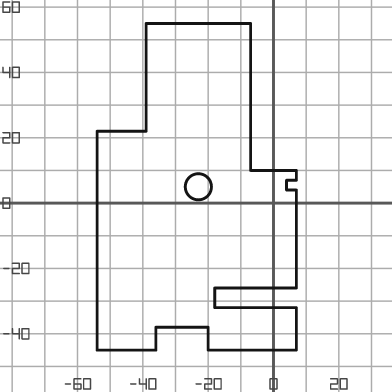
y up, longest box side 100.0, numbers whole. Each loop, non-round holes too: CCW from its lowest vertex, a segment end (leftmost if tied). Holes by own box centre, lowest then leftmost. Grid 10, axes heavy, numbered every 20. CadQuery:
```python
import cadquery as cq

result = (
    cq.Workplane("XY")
    .moveTo(-54.0, -45.0)
    .lineTo(-36.0, -45.0)
    .lineTo(-36.0, -38.0)
    .lineTo(-20.0, -38.0)
    .lineTo(-20.0, -45.0)
    .lineTo(7.0, -45.0)
    .lineTo(7.0, -32.0)
    .lineTo(-18.0, -32.0)
    .lineTo(-18.0, -26.0)
    .lineTo(7.0, -26.0)
    .lineTo(7.0, 4.0)
    .lineTo(4.0, 4.0)
    .lineTo(4.0, 7.0)
    .lineTo(7.0, 7.0)
    .lineTo(7.0, 10.0)
    .lineTo(-7.0, 10.0)
    .lineTo(-7.0, 55.0)
    .lineTo(-39.0, 55.0)
    .lineTo(-39.0, 22.0)
    .lineTo(-54.0, 22.0)
    .close()
    .moveTo(-23.0, 5.0)
    .circle(4.0)
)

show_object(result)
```